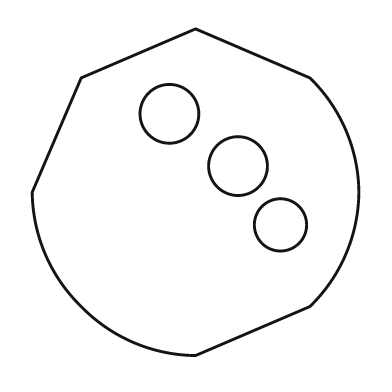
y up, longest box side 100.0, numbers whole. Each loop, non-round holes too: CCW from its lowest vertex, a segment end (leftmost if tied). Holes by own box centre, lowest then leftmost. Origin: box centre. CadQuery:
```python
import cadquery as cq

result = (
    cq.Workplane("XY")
    .moveTo(0.0, -50.0)
    .lineTo(35.0, -35.0)
    .threePointArc((46.0, -19.0), (50.0, 0.0))
    .threePointArc((46.0, 19.0), (35.0, 35.0))
    .lineTo(0.0, 50.0)
    .lineTo(-35.0, 35.0)
    .lineTo(-50.0, 0.0)
    .threePointArc((-46.0, -19.0), (-35.0, -35.0))
    .threePointArc((-19.0, -46.0), (0.0, -50.0))
    .close()
    .moveTo(26.0, -10.0)
    .circle(8.0)
    .moveTo(13.0, 8.0)
    .circle(9.0)
    .moveTo(-8.0, 24.0)
    .circle(9.0)
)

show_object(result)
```